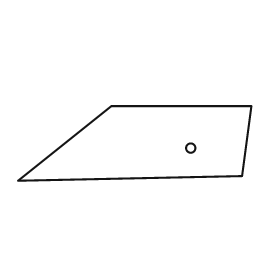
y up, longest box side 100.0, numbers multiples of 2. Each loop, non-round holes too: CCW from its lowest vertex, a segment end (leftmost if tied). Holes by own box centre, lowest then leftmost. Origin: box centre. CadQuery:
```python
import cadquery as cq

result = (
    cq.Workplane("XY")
    .moveTo(-50.0, -16.0)
    .lineTo(46.0, -14.0)
    .lineTo(50.0, 16.0)
    .lineTo(-10.0, 16.0)
    .close()
    .moveTo(24.0, -2.0)
    .circle(2.0)
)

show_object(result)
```